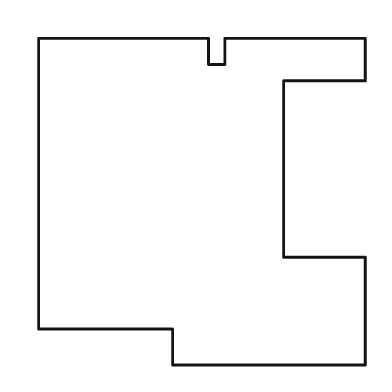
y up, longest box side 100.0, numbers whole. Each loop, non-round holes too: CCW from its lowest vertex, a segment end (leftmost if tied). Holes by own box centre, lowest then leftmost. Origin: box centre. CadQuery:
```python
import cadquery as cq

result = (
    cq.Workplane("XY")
    .moveTo(-9.0, -50.0)
    .lineTo(50.0, -50.0)
    .lineTo(50.0, -17.0)
    .lineTo(25.0, -17.0)
    .lineTo(25.0, 37.0)
    .lineTo(50.0, 37.0)
    .lineTo(50.0, 50.0)
    .lineTo(7.0, 50.0)
    .lineTo(7.0, 42.0)
    .lineTo(2.0, 42.0)
    .lineTo(2.0, 50.0)
    .lineTo(-50.0, 50.0)
    .lineTo(-50.0, -39.0)
    .lineTo(-9.0, -39.0)
    .close()
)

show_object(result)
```